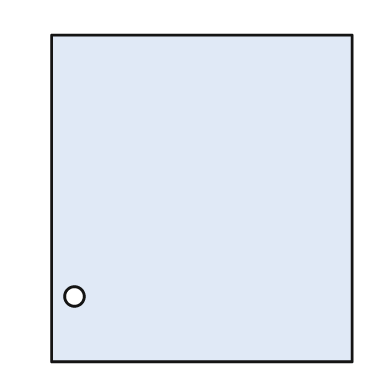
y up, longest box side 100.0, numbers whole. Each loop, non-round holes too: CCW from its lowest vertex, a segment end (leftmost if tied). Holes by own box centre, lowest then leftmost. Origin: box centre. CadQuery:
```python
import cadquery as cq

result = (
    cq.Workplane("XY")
    .moveTo(-46.0, -50.0)
    .lineTo(46.0, -50.0)
    .lineTo(46.0, 50.0)
    .lineTo(-46.0, 50.0)
    .close()
    .moveTo(-39.0, -30.0)
    .circle(3.0)
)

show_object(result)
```